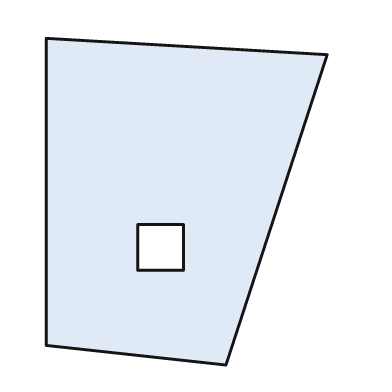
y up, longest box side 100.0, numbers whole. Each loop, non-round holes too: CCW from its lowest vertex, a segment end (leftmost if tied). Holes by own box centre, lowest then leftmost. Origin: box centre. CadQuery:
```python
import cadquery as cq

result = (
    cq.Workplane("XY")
    .moveTo(12.0, -50.0)
    .lineTo(43.0, 45.0)
    .lineTo(-43.0, 50.0)
    .lineTo(-43.0, -44.0)
    .close()
    .moveTo(-15.0, -21.0)
    .lineTo(-1.0, -21.0)
    .lineTo(-1.0, -7.0)
    .lineTo(-15.0, -7.0)
    .close()
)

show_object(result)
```